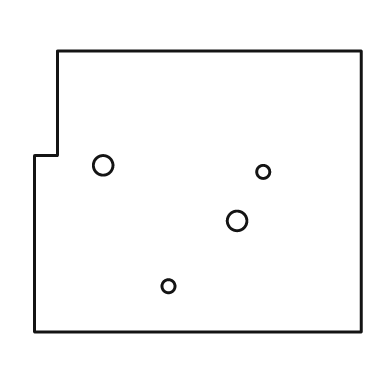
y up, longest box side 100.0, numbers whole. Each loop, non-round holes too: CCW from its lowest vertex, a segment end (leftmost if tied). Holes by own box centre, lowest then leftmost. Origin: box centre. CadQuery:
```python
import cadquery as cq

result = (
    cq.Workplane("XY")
    .moveTo(-50.0, -43.0)
    .lineTo(50.0, -43.0)
    .lineTo(50.0, 43.0)
    .lineTo(-43.0, 43.0)
    .lineTo(-43.0, 11.0)
    .lineTo(-50.0, 11.0)
    .close()
    .moveTo(-9.0, -29.0)
    .circle(2.0)
    .moveTo(12.0, -9.0)
    .circle(3.0)
    .moveTo(20.0, 6.0)
    .circle(2.0)
    .moveTo(-29.0, 8.0)
    .circle(3.0)
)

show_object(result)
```